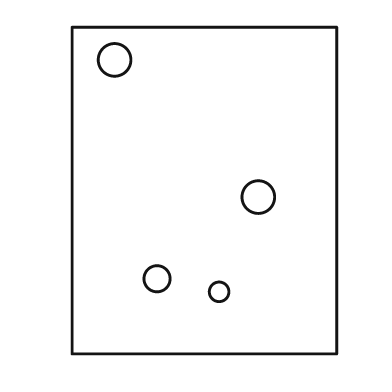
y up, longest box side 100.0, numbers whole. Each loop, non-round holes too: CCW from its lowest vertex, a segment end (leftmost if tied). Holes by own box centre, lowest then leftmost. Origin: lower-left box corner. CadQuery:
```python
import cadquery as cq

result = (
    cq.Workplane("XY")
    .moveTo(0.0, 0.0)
    .lineTo(81.0, 0.0)
    .lineTo(81.0, 100.0)
    .lineTo(0.0, 100.0)
    .close()
    .moveTo(45.0, 19.0)
    .circle(3.0)
    .moveTo(26.0, 23.0)
    .circle(4.0)
    .moveTo(57.0, 48.0)
    .circle(5.0)
    .moveTo(13.0, 90.0)
    .circle(5.0)
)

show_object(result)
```